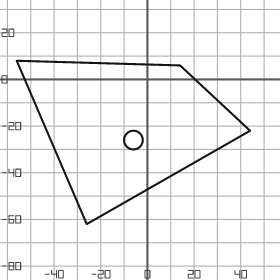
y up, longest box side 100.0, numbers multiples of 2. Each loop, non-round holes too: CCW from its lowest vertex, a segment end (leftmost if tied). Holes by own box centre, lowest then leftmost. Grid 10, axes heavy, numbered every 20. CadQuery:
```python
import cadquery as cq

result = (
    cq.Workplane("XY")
    .moveTo(-26.0, -62.0)
    .lineTo(44.0, -22.0)
    .lineTo(14.0, 6.0)
    .lineTo(-56.0, 8.0)
    .close()
    .moveTo(-6.0, -26.0)
    .circle(4.0)
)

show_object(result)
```